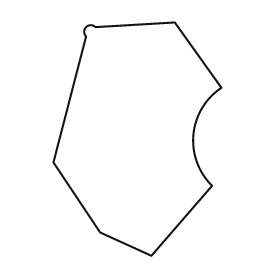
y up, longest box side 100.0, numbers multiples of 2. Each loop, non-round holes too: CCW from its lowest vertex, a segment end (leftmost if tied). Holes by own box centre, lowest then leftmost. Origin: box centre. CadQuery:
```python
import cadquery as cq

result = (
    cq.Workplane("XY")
    .moveTo(6.0, -50.0)
    .lineTo(32.0, -20.0)
    .threePointArc((24.0, 2.0), (36.0, 22.0))
    .lineTo(16.0, 50.0)
    .lineTo(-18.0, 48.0)
    .threePointArc((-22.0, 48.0), (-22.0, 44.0))
    .lineTo(-36.0, -10.0)
    .lineTo(-16.0, -40.0)
    .close()
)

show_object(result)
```